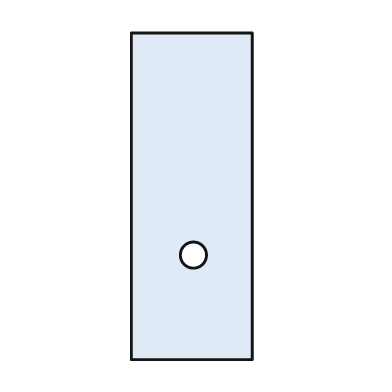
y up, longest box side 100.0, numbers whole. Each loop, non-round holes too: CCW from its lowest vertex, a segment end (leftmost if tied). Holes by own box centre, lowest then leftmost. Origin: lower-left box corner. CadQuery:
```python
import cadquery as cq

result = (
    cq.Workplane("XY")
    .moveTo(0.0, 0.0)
    .lineTo(37.0, 0.0)
    .lineTo(37.0, 100.0)
    .lineTo(0.0, 100.0)
    .close()
    .moveTo(19.0, 32.0)
    .circle(4.0)
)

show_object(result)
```